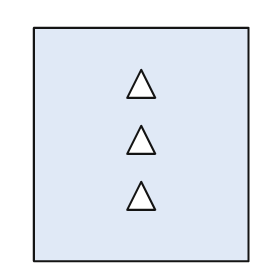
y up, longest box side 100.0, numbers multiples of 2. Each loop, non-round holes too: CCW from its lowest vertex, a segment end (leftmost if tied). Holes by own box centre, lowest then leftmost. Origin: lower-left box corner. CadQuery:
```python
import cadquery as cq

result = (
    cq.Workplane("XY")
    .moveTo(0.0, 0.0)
    .lineTo(92.0, 0.0)
    .lineTo(92.0, 100.0)
    .lineTo(0.0, 100.0)
    .close()
    .moveTo(40.0, 22.0)
    .lineTo(52.0, 22.0)
    .lineTo(46.0, 34.0)
    .close()
    .moveTo(40.0, 46.0)
    .lineTo(52.0, 46.0)
    .lineTo(46.0, 58.0)
    .close()
    .moveTo(40.0, 70.0)
    .lineTo(52.0, 70.0)
    .lineTo(46.0, 82.0)
    .close()
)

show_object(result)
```